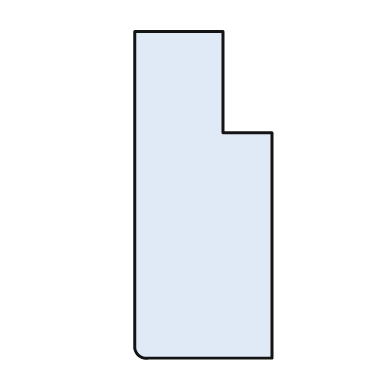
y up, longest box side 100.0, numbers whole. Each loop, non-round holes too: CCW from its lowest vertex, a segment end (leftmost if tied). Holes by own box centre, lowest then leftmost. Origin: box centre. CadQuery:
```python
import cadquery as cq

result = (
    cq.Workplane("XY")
    .moveTo(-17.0, -50.0)
    .lineTo(21.0, -50.0)
    .lineTo(21.0, 19.0)
    .lineTo(6.0, 19.0)
    .lineTo(6.0, 50.0)
    .lineTo(-21.0, 50.0)
    .lineTo(-21.0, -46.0)
    .threePointArc((-20.0, -49.0), (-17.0, -50.0))
    .close()
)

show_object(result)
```